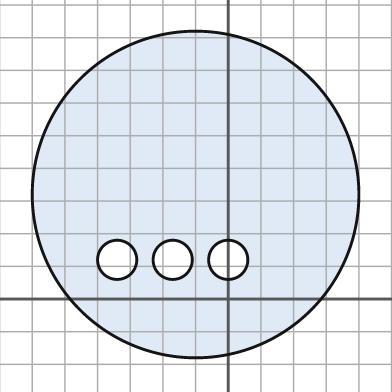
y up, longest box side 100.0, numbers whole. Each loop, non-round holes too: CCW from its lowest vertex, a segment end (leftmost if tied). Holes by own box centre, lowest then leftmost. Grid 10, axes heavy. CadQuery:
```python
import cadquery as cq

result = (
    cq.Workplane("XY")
    .moveTo(-10.0, 32.0)
    .circle(50.0)
    .moveTo(-34.0, 12.0)
    .circle(6.0)
    .moveTo(-17.0, 12.0)
    .circle(6.0)
    .moveTo(0.0, 12.0)
    .circle(6.0)
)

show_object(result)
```